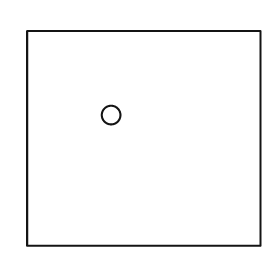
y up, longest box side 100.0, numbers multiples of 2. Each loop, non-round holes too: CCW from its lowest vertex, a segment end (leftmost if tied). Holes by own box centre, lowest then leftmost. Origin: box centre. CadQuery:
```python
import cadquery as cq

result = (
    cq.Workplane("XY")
    .moveTo(-50.0, -46.0)
    .lineTo(50.0, -46.0)
    .lineTo(50.0, 46.0)
    .lineTo(-50.0, 46.0)
    .close()
    .moveTo(-14.0, 10.0)
    .circle(4.0)
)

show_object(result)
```